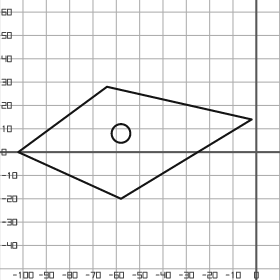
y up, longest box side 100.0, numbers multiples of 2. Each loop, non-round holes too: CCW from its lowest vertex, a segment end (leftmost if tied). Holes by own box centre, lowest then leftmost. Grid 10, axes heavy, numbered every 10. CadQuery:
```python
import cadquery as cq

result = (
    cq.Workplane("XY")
    .moveTo(-58.0, -20.0)
    .lineTo(-2.0, 14.0)
    .lineTo(-64.0, 28.0)
    .lineTo(-102.0, 0.0)
    .close()
    .moveTo(-58.0, 8.0)
    .circle(4.0)
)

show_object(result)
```